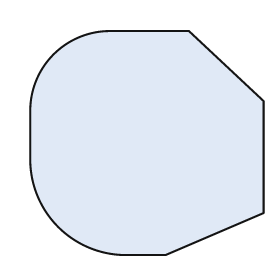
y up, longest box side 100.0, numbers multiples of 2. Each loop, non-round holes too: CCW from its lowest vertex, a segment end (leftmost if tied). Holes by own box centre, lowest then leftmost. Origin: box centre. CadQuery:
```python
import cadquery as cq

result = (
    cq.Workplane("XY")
    .moveTo(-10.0, -48.0)
    .lineTo(8.0, -48.0)
    .lineTo(50.0, -30.0)
    .lineTo(50.0, 18.0)
    .lineTo(18.0, 48.0)
    .lineTo(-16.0, 48.0)
    .threePointArc((-40.0, 38.0), (-50.0, 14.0))
    .lineTo(-50.0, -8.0)
    .threePointArc((-38.0, -36.0), (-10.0, -48.0))
    .close()
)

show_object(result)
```